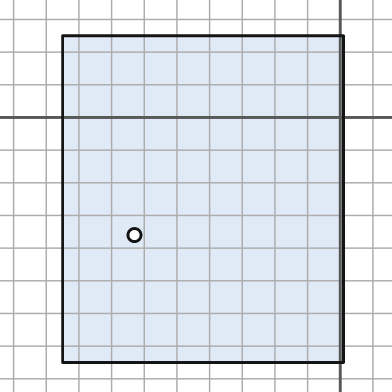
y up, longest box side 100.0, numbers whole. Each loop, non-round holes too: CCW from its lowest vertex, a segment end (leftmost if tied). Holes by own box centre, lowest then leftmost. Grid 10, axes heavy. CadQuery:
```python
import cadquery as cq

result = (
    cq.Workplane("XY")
    .moveTo(-85.0, -75.0)
    .lineTo(1.0, -75.0)
    .lineTo(1.0, 25.0)
    .lineTo(-85.0, 25.0)
    .close()
    .moveTo(-63.0, -36.0)
    .circle(2.0)
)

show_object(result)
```